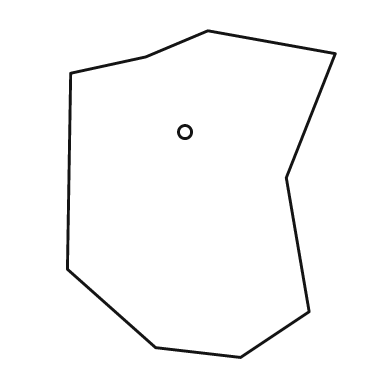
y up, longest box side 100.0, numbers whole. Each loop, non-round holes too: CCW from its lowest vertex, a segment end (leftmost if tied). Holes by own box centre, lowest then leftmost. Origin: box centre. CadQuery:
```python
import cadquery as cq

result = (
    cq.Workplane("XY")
    .moveTo(12.0, -50.0)
    .lineTo(33.0, -36.0)
    .lineTo(26.0, 5.0)
    .lineTo(41.0, 43.0)
    .lineTo(2.0, 50.0)
    .lineTo(-17.0, 42.0)
    .lineTo(-40.0, 37.0)
    .lineTo(-41.0, -23.0)
    .lineTo(-14.0, -47.0)
    .close()
    .moveTo(-5.0, 19.0)
    .circle(2.0)
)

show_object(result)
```